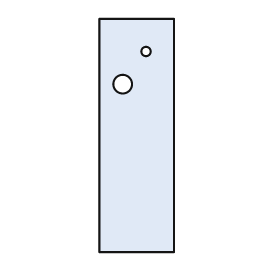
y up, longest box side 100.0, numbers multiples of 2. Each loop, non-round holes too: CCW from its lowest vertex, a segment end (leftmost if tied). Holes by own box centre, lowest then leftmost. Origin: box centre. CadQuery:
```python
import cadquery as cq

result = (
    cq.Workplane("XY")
    .moveTo(-16.0, -50.0)
    .lineTo(16.0, -50.0)
    .lineTo(16.0, 50.0)
    .lineTo(-16.0, 50.0)
    .close()
    .moveTo(-6.0, 22.0)
    .circle(4.0)
    .moveTo(4.0, 36.0)
    .circle(2.0)
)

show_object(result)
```